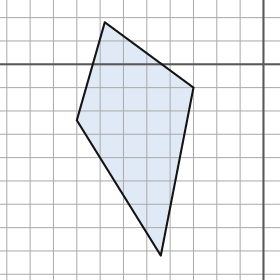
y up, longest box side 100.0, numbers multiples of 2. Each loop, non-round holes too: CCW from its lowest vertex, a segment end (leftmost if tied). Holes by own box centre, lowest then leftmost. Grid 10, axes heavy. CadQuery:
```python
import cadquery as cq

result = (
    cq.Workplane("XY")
    .moveTo(-44.0, -82.0)
    .lineTo(-30.0, -10.0)
    .lineTo(-68.0, 18.0)
    .lineTo(-80.0, -24.0)
    .close()
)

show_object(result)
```